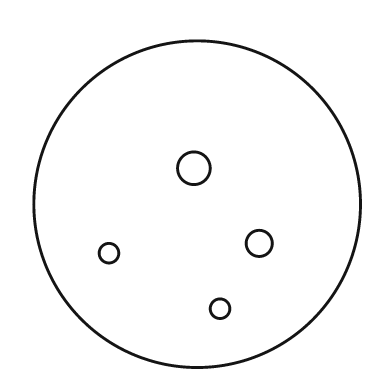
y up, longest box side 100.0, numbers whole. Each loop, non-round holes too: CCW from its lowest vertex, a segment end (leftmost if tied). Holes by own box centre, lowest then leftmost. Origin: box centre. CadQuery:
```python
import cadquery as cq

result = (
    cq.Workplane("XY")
    .moveTo(0.0, 0.0)
    .circle(50.0)
    .moveTo(7.0, -32.0)
    .circle(3.0)
    .moveTo(-27.0, -15.0)
    .circle(3.0)
    .moveTo(19.0, -12.0)
    .circle(4.0)
    .moveTo(-1.0, 11.0)
    .circle(5.0)
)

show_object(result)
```